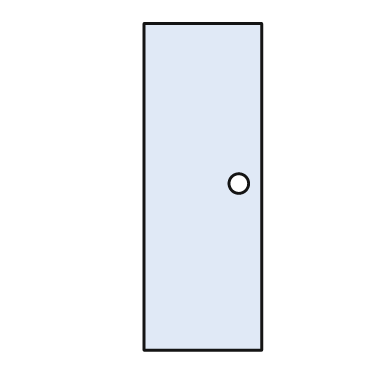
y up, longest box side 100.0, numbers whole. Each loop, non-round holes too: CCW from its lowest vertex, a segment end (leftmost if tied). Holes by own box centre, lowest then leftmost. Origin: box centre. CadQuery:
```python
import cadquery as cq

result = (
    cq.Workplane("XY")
    .moveTo(-18.0, -50.0)
    .lineTo(18.0, -50.0)
    .lineTo(18.0, 50.0)
    .lineTo(-18.0, 50.0)
    .close()
    .moveTo(11.0, 1.0)
    .circle(3.0)
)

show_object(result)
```